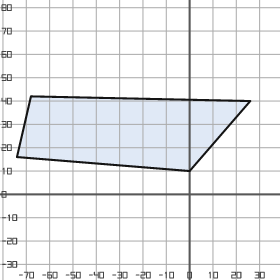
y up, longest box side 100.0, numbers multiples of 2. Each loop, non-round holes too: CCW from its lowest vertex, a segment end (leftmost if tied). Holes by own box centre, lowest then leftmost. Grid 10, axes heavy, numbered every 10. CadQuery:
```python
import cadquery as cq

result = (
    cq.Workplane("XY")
    .moveTo(0.0, 10.0)
    .lineTo(26.0, 40.0)
    .lineTo(-68.0, 42.0)
    .lineTo(-74.0, 16.0)
    .close()
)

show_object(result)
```